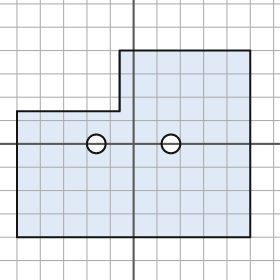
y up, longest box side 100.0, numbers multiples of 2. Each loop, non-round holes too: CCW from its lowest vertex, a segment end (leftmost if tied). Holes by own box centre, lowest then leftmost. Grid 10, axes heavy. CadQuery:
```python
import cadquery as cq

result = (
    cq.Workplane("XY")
    .moveTo(-50.0, -40.0)
    .lineTo(50.0, -40.0)
    .lineTo(50.0, 40.0)
    .lineTo(-6.0, 40.0)
    .lineTo(-6.0, 14.0)
    .lineTo(-50.0, 14.0)
    .close()
    .moveTo(-16.0, 0.0)
    .circle(4.0)
    .moveTo(16.0, 0.0)
    .circle(4.0)
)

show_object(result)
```